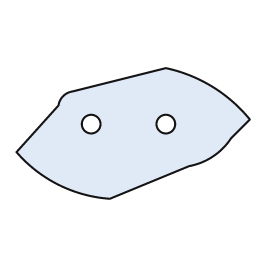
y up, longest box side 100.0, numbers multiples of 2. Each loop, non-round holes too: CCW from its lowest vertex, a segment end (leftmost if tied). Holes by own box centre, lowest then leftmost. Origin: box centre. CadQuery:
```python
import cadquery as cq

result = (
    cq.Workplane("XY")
    .moveTo(-10.0, -28.0)
    .lineTo(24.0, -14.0)
    .threePointArc((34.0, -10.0), (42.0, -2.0))
    .lineTo(50.0, 6.0)
    .threePointArc((34.0, 20.0), (14.0, 28.0))
    .lineTo(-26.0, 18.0)
    .threePointArc((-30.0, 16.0), (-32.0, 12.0))
    .lineTo(-50.0, -8.0)
    .threePointArc((-32.0, -22.0), (-10.0, -28.0))
    .close()
    .moveTo(-18.0, 4.0)
    .circle(4.0)
    .moveTo(14.0, 4.0)
    .circle(4.0)
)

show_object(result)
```